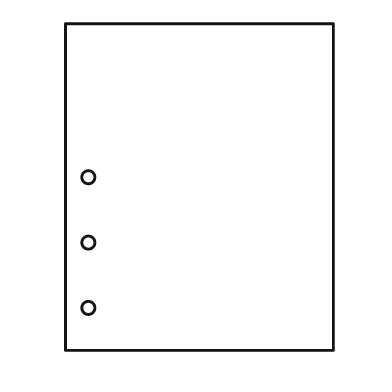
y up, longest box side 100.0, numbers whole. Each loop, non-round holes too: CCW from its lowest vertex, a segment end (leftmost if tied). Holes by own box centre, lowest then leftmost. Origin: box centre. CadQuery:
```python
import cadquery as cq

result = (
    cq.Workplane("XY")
    .moveTo(-41.0, -50.0)
    .lineTo(41.0, -50.0)
    .lineTo(41.0, 50.0)
    .lineTo(-41.0, 50.0)
    .close()
    .moveTo(-34.0, -37.0)
    .circle(2.0)
    .moveTo(-34.0, -17.0)
    .circle(2.0)
    .moveTo(-34.0, 3.0)
    .circle(2.0)
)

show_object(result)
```